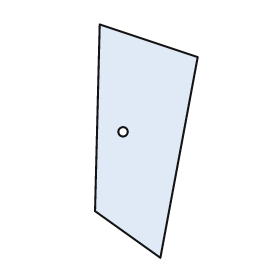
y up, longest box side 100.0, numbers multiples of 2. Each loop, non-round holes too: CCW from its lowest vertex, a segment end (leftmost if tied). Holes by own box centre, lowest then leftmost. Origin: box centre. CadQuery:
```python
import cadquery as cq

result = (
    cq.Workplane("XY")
    .moveTo(6.0, -50.0)
    .lineTo(22.0, 36.0)
    .lineTo(-20.0, 50.0)
    .lineTo(-22.0, -30.0)
    .close()
    .moveTo(-10.0, 4.0)
    .circle(2.0)
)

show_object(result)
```